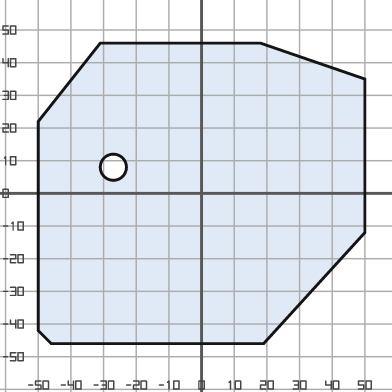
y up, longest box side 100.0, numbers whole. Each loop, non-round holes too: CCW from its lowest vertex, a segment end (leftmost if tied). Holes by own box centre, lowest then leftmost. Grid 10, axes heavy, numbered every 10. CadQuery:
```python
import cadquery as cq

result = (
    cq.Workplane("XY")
    .moveTo(-46.0, -46.0)
    .lineTo(19.0, -46.0)
    .lineTo(50.0, -12.0)
    .lineTo(50.0, 35.0)
    .lineTo(18.0, 46.0)
    .lineTo(-31.0, 46.0)
    .lineTo(-50.0, 22.0)
    .lineTo(-50.0, -42.0)
    .close()
    .moveTo(-27.0, 8.0)
    .circle(4.0)
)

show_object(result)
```